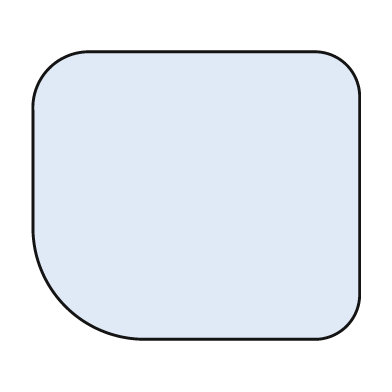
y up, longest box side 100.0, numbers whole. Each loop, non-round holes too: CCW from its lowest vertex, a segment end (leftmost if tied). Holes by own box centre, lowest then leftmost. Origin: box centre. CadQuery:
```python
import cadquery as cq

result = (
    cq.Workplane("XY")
    .moveTo(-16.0, -44.0)
    .lineTo(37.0, -44.0)
    .threePointArc((46.0, -40.0), (50.0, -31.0))
    .lineTo(50.0, 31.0)
    .threePointArc((46.0, 40.0), (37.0, 44.0))
    .lineTo(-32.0, 44.0)
    .threePointArc((-45.0, 39.0), (-50.0, 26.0))
    .lineTo(-50.0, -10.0)
    .threePointArc((-40.0, -34.0), (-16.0, -44.0))
    .close()
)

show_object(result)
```